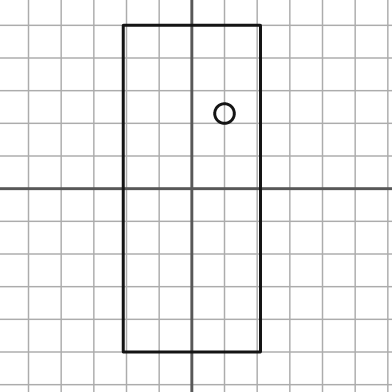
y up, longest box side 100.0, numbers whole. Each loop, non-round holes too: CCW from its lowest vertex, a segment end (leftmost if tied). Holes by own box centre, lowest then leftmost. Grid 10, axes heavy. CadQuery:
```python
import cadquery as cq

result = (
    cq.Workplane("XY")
    .moveTo(-21.0, -50.0)
    .lineTo(21.0, -50.0)
    .lineTo(21.0, 50.0)
    .lineTo(-21.0, 50.0)
    .close()
    .moveTo(10.0, 23.0)
    .circle(3.0)
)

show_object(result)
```